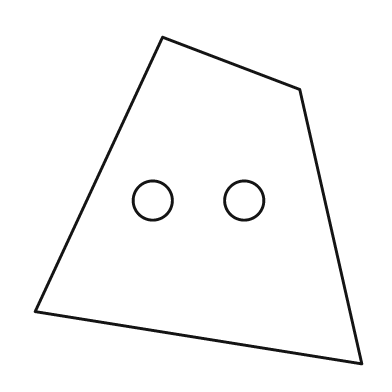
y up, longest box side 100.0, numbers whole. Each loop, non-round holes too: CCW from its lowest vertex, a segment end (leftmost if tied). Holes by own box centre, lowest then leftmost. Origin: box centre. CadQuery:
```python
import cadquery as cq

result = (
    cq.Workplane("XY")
    .moveTo(50.0, -50.0)
    .lineTo(31.0, 34.0)
    .lineTo(-11.0, 50.0)
    .lineTo(-50.0, -34.0)
    .close()
    .moveTo(-14.0, 0.0)
    .circle(6.0)
    .moveTo(14.0, 0.0)
    .circle(6.0)
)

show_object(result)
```